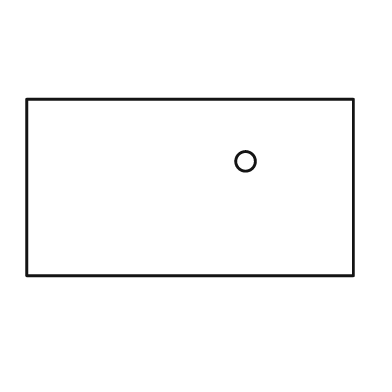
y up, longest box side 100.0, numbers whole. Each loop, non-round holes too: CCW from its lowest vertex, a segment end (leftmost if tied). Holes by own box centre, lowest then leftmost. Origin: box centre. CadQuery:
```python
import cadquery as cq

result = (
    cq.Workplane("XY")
    .moveTo(-50.0, -27.0)
    .lineTo(50.0, -27.0)
    .lineTo(50.0, 27.0)
    .lineTo(-50.0, 27.0)
    .close()
    .moveTo(17.0, 8.0)
    .circle(3.0)
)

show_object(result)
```